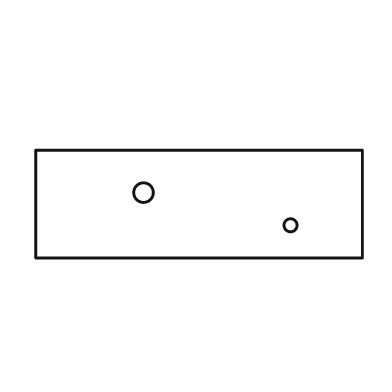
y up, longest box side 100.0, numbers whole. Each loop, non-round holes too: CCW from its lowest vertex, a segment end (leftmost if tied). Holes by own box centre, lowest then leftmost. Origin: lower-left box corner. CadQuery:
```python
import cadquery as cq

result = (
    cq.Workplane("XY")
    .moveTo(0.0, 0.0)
    .lineTo(100.0, 0.0)
    .lineTo(100.0, 33.0)
    .lineTo(0.0, 33.0)
    .close()
    .moveTo(78.0, 10.0)
    .circle(2.0)
    .moveTo(33.0, 20.0)
    .circle(3.0)
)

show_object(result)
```